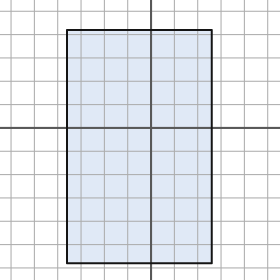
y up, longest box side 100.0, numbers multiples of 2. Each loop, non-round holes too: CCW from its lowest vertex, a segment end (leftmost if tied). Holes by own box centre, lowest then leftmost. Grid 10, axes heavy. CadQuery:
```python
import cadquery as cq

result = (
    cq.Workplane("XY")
    .moveTo(-36.0, -58.0)
    .lineTo(26.0, -58.0)
    .lineTo(26.0, 42.0)
    .lineTo(-36.0, 42.0)
    .close()
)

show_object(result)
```